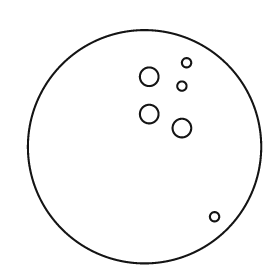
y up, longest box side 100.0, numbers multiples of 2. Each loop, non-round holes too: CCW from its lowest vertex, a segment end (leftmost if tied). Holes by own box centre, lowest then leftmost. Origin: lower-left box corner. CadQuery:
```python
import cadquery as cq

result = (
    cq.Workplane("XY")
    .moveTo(50.0, 50.0)
    .circle(50.0)
    .moveTo(80.0, 20.0)
    .circle(2.0)
    .moveTo(66.0, 58.0)
    .circle(4.0)
    .moveTo(52.0, 64.0)
    .circle(4.0)
    .moveTo(66.0, 76.0)
    .circle(2.0)
    .moveTo(52.0, 80.0)
    .circle(4.0)
    .moveTo(68.0, 86.0)
    .circle(2.0)
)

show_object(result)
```